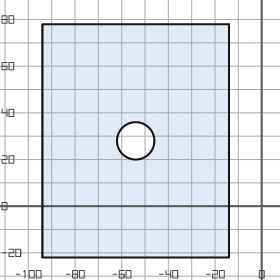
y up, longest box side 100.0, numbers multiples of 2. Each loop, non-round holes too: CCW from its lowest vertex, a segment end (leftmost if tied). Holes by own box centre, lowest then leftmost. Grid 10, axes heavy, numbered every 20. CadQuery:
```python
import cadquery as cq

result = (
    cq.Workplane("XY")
    .moveTo(-94.0, -22.0)
    .lineTo(-14.0, -22.0)
    .lineTo(-14.0, 78.0)
    .lineTo(-94.0, 78.0)
    .close()
    .moveTo(-54.0, 28.0)
    .circle(8.0)
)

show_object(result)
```